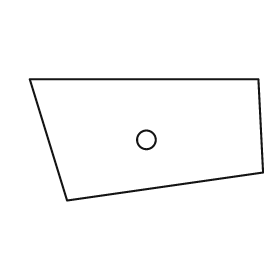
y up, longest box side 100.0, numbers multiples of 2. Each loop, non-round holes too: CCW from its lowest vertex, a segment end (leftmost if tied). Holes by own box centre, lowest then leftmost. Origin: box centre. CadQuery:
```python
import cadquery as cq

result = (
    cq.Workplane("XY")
    .moveTo(-34.0, -26.0)
    .lineTo(50.0, -14.0)
    .lineTo(48.0, 26.0)
    .lineTo(-50.0, 26.0)
    .close()
    .moveTo(0.0, 0.0)
    .circle(4.0)
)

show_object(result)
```